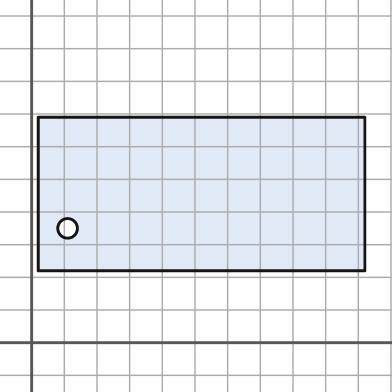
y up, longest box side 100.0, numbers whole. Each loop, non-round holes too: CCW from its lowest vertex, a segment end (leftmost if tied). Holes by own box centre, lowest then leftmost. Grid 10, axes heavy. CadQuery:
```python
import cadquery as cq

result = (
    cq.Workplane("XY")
    .moveTo(2.0, 22.0)
    .lineTo(102.0, 22.0)
    .lineTo(102.0, 69.0)
    .lineTo(2.0, 69.0)
    .close()
    .moveTo(11.0, 35.0)
    .circle(3.0)
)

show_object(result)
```